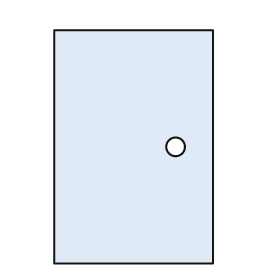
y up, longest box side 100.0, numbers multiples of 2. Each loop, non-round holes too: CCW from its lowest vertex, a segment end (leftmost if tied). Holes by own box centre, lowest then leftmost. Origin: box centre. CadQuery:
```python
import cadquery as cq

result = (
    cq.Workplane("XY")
    .moveTo(-34.0, -50.0)
    .lineTo(34.0, -50.0)
    .lineTo(34.0, 50.0)
    .lineTo(-34.0, 50.0)
    .close()
    .moveTo(18.0, 0.0)
    .circle(4.0)
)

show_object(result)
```